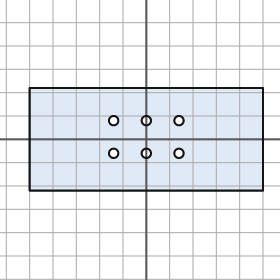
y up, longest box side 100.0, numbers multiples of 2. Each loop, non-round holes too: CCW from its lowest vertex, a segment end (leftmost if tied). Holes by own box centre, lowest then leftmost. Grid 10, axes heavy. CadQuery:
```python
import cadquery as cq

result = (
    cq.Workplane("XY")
    .moveTo(-50.0, -22.0)
    .lineTo(50.0, -22.0)
    .lineTo(50.0, 22.0)
    .lineTo(-50.0, 22.0)
    .close()
    .moveTo(-14.0, -6.0)
    .circle(2.0)
    .moveTo(0.0, -6.0)
    .circle(2.0)
    .moveTo(14.0, -6.0)
    .circle(2.0)
    .moveTo(-14.0, 8.0)
    .circle(2.0)
    .moveTo(0.0, 8.0)
    .circle(2.0)
    .moveTo(14.0, 8.0)
    .circle(2.0)
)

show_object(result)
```